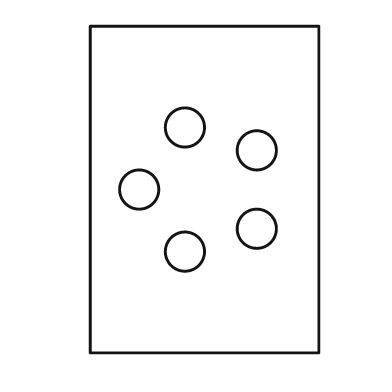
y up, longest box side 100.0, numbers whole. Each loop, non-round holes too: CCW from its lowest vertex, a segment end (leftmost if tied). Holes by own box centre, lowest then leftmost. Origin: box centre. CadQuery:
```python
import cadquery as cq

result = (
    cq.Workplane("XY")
    .moveTo(-35.0, -50.0)
    .lineTo(35.0, -50.0)
    .lineTo(35.0, 50.0)
    .lineTo(-35.0, 50.0)
    .close()
    .moveTo(-6.0, -19.0)
    .circle(6.0)
    .moveTo(16.0, -12.0)
    .circle(6.0)
    .moveTo(-20.0, 0.0)
    .circle(6.0)
    .moveTo(16.0, 12.0)
    .circle(6.0)
    .moveTo(-6.0, 19.0)
    .circle(6.0)
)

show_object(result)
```